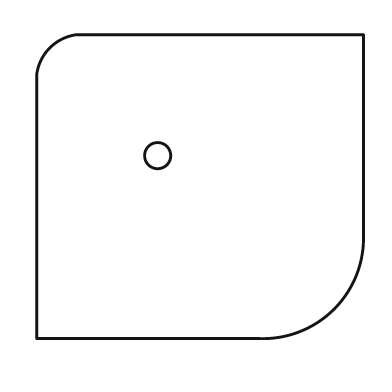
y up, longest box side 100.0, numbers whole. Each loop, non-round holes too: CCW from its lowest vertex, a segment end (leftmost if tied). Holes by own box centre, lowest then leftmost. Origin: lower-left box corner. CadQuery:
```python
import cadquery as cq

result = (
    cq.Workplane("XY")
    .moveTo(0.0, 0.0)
    .lineTo(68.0, 0.0)
    .threePointArc((91.0, 9.0), (100.0, 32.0))
    .lineTo(100.0, 93.0)
    .lineTo(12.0, 93.0)
    .threePointArc((4.0, 89.0), (0.0, 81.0))
    .close()
    .moveTo(37.0, 56.0)
    .circle(4.0)
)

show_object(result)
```